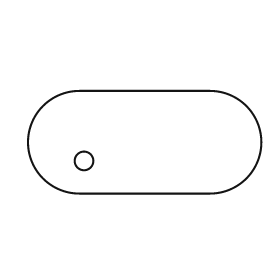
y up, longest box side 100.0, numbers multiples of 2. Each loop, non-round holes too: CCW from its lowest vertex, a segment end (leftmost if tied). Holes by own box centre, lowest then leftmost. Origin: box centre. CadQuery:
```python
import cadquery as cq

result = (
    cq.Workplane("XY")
    .moveTo(-28.0, -22.0)
    .lineTo(28.0, -22.0)
    .threePointArc((50.0, 0.0), (28.0, 22.0))
    .lineTo(-28.0, 22.0)
    .threePointArc((-50.0, 0.0), (-28.0, -22.0))
    .close()
    .moveTo(-26.0, -8.0)
    .circle(4.0)
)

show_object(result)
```